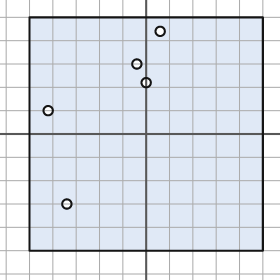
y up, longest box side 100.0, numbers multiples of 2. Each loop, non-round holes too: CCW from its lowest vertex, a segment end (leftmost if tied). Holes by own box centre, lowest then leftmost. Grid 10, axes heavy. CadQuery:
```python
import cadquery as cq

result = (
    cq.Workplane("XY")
    .moveTo(-50.0, -50.0)
    .lineTo(50.0, -50.0)
    .lineTo(50.0, 50.0)
    .lineTo(-50.0, 50.0)
    .close()
    .moveTo(-34.0, -30.0)
    .circle(2.0)
    .moveTo(-42.0, 10.0)
    .circle(2.0)
    .moveTo(0.0, 22.0)
    .circle(2.0)
    .moveTo(-4.0, 30.0)
    .circle(2.0)
    .moveTo(6.0, 44.0)
    .circle(2.0)
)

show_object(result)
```